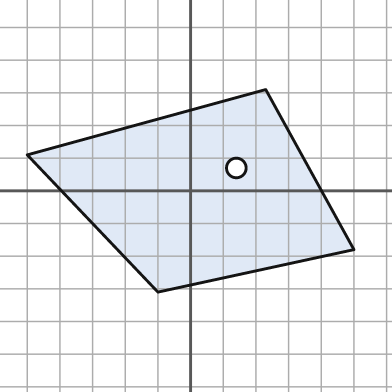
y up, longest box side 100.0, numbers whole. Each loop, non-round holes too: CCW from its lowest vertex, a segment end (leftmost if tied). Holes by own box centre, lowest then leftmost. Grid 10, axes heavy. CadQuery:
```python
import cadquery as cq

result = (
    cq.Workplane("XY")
    .moveTo(-10.0, -31.0)
    .lineTo(50.0, -18.0)
    .lineTo(23.0, 31.0)
    .lineTo(-50.0, 11.0)
    .close()
    .moveTo(14.0, 7.0)
    .circle(3.0)
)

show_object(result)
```